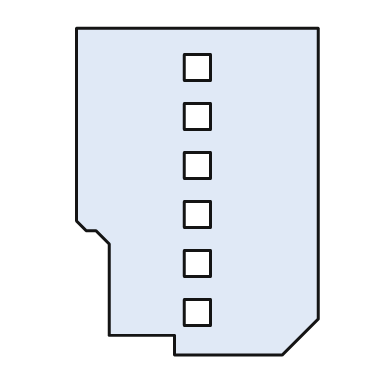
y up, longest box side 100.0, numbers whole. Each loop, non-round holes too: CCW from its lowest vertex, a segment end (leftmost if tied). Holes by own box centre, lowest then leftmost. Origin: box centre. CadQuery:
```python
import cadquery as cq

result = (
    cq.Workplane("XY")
    .moveTo(-7.0, -50.0)
    .lineTo(26.0, -50.0)
    .lineTo(37.0, -39.0)
    .lineTo(37.0, 50.0)
    .lineTo(-37.0, 50.0)
    .lineTo(-37.0, -9.0)
    .lineTo(-34.0, -12.0)
    .lineTo(-31.0, -12.0)
    .lineTo(-27.0, -16.0)
    .lineTo(-27.0, -44.0)
    .lineTo(-7.0, -44.0)
    .close()
    .moveTo(-4.0, -41.0)
    .lineTo(4.0, -41.0)
    .lineTo(4.0, -33.0)
    .lineTo(-4.0, -33.0)
    .close()
    .moveTo(-4.0, -26.0)
    .lineTo(4.0, -26.0)
    .lineTo(4.0, -18.0)
    .lineTo(-4.0, -18.0)
    .close()
    .moveTo(-4.0, -11.0)
    .lineTo(4.0, -11.0)
    .lineTo(4.0, -3.0)
    .lineTo(-4.0, -3.0)
    .close()
    .moveTo(-4.0, 4.0)
    .lineTo(4.0, 4.0)
    .lineTo(4.0, 12.0)
    .lineTo(-4.0, 12.0)
    .close()
    .moveTo(-4.0, 19.0)
    .lineTo(4.0, 19.0)
    .lineTo(4.0, 27.0)
    .lineTo(-4.0, 27.0)
    .close()
    .moveTo(-4.0, 34.0)
    .lineTo(4.0, 34.0)
    .lineTo(4.0, 42.0)
    .lineTo(-4.0, 42.0)
    .close()
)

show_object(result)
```